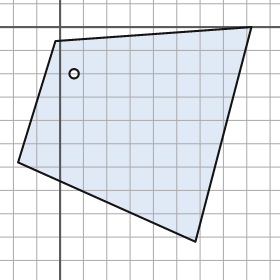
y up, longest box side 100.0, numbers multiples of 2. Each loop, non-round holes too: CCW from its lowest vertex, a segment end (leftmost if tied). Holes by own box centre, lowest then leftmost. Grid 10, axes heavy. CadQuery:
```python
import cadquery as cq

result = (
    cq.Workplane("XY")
    .moveTo(58.0, -92.0)
    .lineTo(82.0, 0.0)
    .lineTo(-2.0, -6.0)
    .lineTo(-18.0, -58.0)
    .close()
    .moveTo(6.0, -20.0)
    .circle(2.0)
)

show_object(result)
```